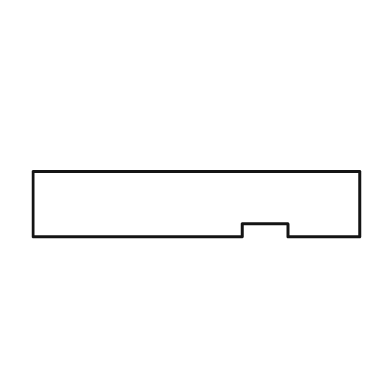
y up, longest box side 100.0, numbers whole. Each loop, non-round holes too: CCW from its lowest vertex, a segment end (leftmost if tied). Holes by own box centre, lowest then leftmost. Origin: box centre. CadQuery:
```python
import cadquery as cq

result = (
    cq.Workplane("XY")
    .moveTo(-50.0, -10.0)
    .lineTo(14.0, -10.0)
    .lineTo(14.0, -6.0)
    .lineTo(28.0, -6.0)
    .lineTo(28.0, -10.0)
    .lineTo(50.0, -10.0)
    .lineTo(50.0, 10.0)
    .lineTo(-50.0, 10.0)
    .close()
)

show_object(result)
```